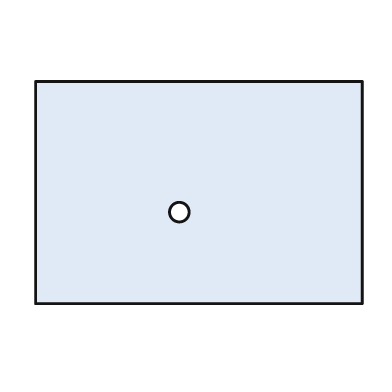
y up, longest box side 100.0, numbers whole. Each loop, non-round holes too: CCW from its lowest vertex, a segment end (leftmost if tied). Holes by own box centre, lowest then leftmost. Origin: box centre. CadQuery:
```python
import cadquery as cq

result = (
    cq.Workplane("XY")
    .moveTo(-50.0, -34.0)
    .lineTo(50.0, -34.0)
    .lineTo(50.0, 34.0)
    .lineTo(-50.0, 34.0)
    .close()
    .moveTo(-6.0, -6.0)
    .circle(3.0)
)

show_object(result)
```